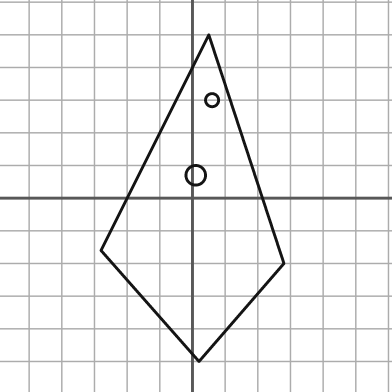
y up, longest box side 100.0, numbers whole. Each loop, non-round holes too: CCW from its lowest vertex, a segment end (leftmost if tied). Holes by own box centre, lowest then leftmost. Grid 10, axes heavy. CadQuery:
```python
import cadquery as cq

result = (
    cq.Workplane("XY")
    .moveTo(2.0, -50.0)
    .lineTo(28.0, -20.0)
    .lineTo(5.0, 50.0)
    .lineTo(-28.0, -16.0)
    .close()
    .moveTo(1.0, 7.0)
    .circle(3.0)
    .moveTo(6.0, 30.0)
    .circle(2.0)
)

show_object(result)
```